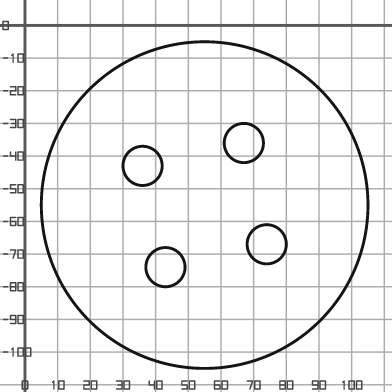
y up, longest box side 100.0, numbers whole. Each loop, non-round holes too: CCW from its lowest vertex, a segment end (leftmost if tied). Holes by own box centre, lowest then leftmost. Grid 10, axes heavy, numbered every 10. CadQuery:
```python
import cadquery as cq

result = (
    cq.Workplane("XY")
    .moveTo(55.0, -55.0)
    .circle(50.0)
    .moveTo(43.0, -74.0)
    .circle(6.0)
    .moveTo(74.0, -67.0)
    .circle(6.0)
    .moveTo(36.0, -43.0)
    .circle(6.0)
    .moveTo(67.0, -36.0)
    .circle(6.0)
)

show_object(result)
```